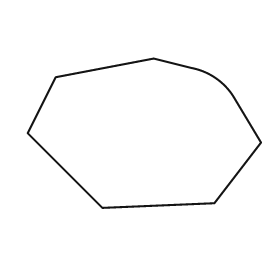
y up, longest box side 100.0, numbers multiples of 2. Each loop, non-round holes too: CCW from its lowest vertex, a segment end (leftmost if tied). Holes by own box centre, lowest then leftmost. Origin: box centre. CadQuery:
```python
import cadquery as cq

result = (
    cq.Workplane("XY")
    .moveTo(-18.0, -32.0)
    .lineTo(30.0, -30.0)
    .lineTo(50.0, -4.0)
    .lineTo(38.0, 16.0)
    .threePointArc((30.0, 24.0), (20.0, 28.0))
    .lineTo(4.0, 32.0)
    .lineTo(-38.0, 24.0)
    .lineTo(-50.0, 0.0)
    .close()
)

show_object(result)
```